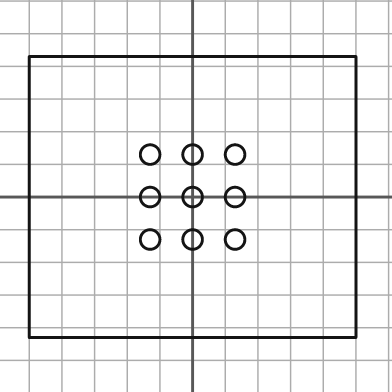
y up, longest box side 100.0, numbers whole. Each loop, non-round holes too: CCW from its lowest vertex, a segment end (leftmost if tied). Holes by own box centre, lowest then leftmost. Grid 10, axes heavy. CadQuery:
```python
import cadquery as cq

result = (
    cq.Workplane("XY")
    .moveTo(-50.0, -43.0)
    .lineTo(50.0, -43.0)
    .lineTo(50.0, 43.0)
    .lineTo(-50.0, 43.0)
    .close()
    .moveTo(-13.0, -13.0)
    .circle(3.0)
    .moveTo(0.0, -13.0)
    .circle(3.0)
    .moveTo(13.0, -13.0)
    .circle(3.0)
    .moveTo(-13.0, 0.0)
    .circle(3.0)
    .moveTo(0.0, 0.0)
    .circle(3.0)
    .moveTo(13.0, 0.0)
    .circle(3.0)
    .moveTo(-13.0, 13.0)
    .circle(3.0)
    .moveTo(0.0, 13.0)
    .circle(3.0)
    .moveTo(13.0, 13.0)
    .circle(3.0)
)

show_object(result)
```